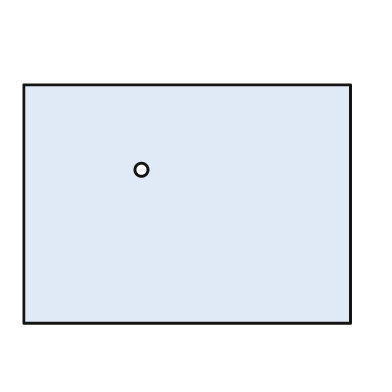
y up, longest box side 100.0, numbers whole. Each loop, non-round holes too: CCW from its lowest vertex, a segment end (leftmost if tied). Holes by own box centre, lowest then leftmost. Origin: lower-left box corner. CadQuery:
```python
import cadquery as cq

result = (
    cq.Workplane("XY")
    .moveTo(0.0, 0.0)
    .lineTo(100.0, 0.0)
    .lineTo(100.0, 73.0)
    .lineTo(0.0, 73.0)
    .close()
    .moveTo(36.0, 47.0)
    .circle(2.0)
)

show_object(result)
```